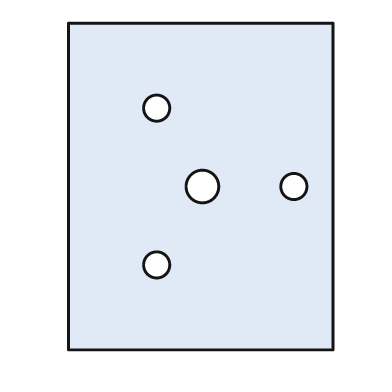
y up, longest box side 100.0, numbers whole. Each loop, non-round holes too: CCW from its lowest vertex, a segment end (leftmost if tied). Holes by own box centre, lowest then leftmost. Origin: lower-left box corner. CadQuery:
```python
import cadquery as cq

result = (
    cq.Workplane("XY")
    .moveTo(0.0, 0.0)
    .lineTo(81.0, 0.0)
    .lineTo(81.0, 100.0)
    .lineTo(0.0, 100.0)
    .close()
    .moveTo(27.0, 26.0)
    .circle(4.0)
    .moveTo(41.0, 50.0)
    .circle(5.0)
    .moveTo(69.0, 50.0)
    .circle(4.0)
    .moveTo(27.0, 74.0)
    .circle(4.0)
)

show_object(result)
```